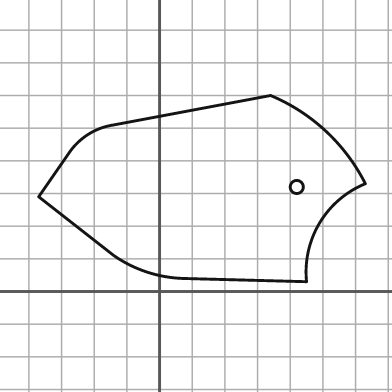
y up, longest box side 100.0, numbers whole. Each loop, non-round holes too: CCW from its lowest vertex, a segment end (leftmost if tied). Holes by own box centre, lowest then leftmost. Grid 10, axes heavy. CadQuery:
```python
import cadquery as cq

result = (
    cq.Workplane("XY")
    .moveTo(45.0, 3.0)
    .threePointArc((49.0, 21.0), (63.0, 33.0))
    .threePointArc((51.0, 49.0), (34.0, 60.0))
    .lineTo(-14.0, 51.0)
    .threePointArc((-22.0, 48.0), (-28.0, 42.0))
    .lineTo(-37.0, 29.0)
    .lineTo(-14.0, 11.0)
    .threePointArc((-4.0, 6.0), (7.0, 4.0))
    .close()
    .moveTo(42.0, 32.0)
    .circle(2.0)
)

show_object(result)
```